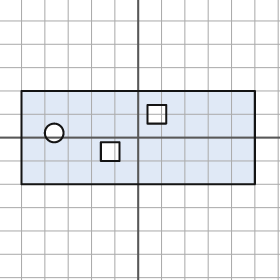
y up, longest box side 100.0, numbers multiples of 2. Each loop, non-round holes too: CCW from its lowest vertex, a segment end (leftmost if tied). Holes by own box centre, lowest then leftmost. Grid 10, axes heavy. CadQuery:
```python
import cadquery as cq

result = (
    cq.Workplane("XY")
    .moveTo(-50.0, -20.0)
    .lineTo(50.0, -20.0)
    .lineTo(50.0, 20.0)
    .lineTo(-50.0, 20.0)
    .close()
    .moveTo(-16.0, -10.0)
    .lineTo(-8.0, -10.0)
    .lineTo(-8.0, -2.0)
    .lineTo(-16.0, -2.0)
    .close()
    .moveTo(-36.0, 2.0)
    .circle(4.0)
    .moveTo(4.0, 6.0)
    .lineTo(12.0, 6.0)
    .lineTo(12.0, 14.0)
    .lineTo(4.0, 14.0)
    .close()
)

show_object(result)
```